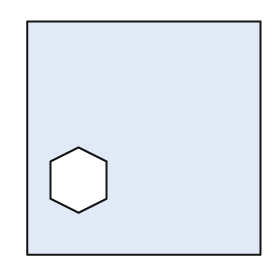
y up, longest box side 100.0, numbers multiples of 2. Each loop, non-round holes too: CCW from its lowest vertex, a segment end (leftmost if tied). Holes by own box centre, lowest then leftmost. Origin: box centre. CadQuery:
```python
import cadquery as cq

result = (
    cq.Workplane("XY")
    .moveTo(-50.0, -50.0)
    .lineTo(50.0, -50.0)
    .lineTo(50.0, 50.0)
    .lineTo(-50.0, 50.0)
    .close()
    .moveTo(-28.0, -32.0)
    .lineTo(-16.0, -26.0)
    .lineTo(-16.0, -10.0)
    .lineTo(-28.0, -4.0)
    .lineTo(-40.0, -10.0)
    .lineTo(-40.0, -26.0)
    .close()
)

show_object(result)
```